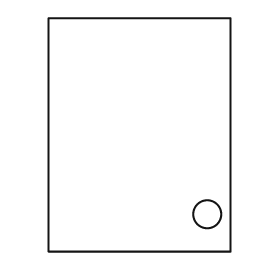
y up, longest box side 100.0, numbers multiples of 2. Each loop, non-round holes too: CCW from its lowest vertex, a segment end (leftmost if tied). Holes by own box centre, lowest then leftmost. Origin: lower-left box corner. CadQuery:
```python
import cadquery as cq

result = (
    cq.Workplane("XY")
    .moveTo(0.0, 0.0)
    .lineTo(78.0, 0.0)
    .lineTo(78.0, 100.0)
    .lineTo(0.0, 100.0)
    .close()
    .moveTo(68.0, 16.0)
    .circle(6.0)
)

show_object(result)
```